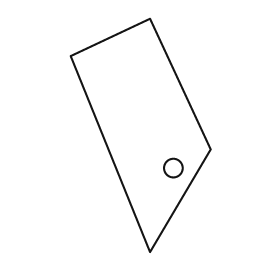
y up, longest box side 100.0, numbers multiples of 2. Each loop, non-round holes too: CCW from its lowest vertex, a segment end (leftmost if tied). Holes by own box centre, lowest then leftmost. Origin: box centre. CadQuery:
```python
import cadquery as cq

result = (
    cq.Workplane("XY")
    .moveTo(4.0, -50.0)
    .lineTo(30.0, -6.0)
    .lineTo(4.0, 50.0)
    .lineTo(-30.0, 34.0)
    .close()
    .moveTo(14.0, -14.0)
    .circle(4.0)
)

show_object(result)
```